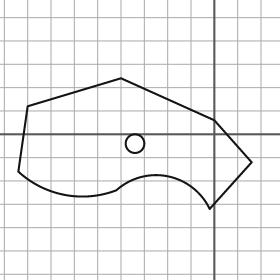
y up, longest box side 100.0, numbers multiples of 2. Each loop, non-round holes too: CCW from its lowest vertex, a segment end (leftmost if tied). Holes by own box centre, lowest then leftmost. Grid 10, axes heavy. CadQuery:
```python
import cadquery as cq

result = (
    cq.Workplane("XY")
    .moveTo(-2.0, -32.0)
    .lineTo(16.0, -12.0)
    .lineTo(0.0, 6.0)
    .lineTo(-40.0, 24.0)
    .lineTo(-80.0, 12.0)
    .lineTo(-84.0, -16.0)
    .threePointArc((-64.0, -26.0), (-42.0, -24.0))
    .threePointArc((-20.0, -18.0), (-2.0, -32.0))
    .close()
    .moveTo(-34.0, -4.0)
    .circle(4.0)
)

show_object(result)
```